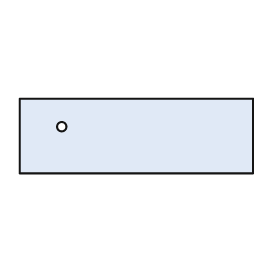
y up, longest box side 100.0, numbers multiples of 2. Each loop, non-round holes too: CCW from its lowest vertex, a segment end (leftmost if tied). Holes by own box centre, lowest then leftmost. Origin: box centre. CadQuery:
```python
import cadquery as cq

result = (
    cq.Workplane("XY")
    .moveTo(-50.0, -16.0)
    .lineTo(50.0, -16.0)
    .lineTo(50.0, 16.0)
    .lineTo(-50.0, 16.0)
    .close()
    .moveTo(-32.0, 4.0)
    .circle(2.0)
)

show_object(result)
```